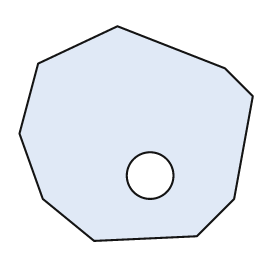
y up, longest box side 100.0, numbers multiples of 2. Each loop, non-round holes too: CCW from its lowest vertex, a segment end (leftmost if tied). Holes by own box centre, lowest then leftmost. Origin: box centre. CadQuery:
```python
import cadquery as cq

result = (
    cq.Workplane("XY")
    .moveTo(-18.0, -46.0)
    .lineTo(26.0, -44.0)
    .lineTo(42.0, -28.0)
    .lineTo(50.0, 16.0)
    .lineTo(38.0, 28.0)
    .lineTo(-8.0, 46.0)
    .lineTo(-42.0, 30.0)
    .lineTo(-50.0, 0.0)
    .lineTo(-40.0, -28.0)
    .close()
    .moveTo(6.0, -18.0)
    .circle(10.0)
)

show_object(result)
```